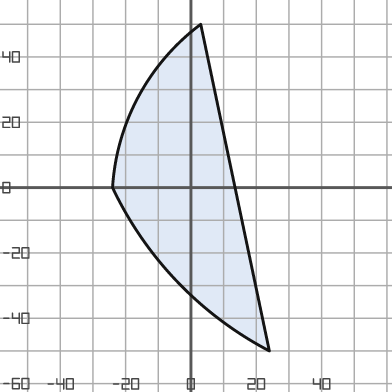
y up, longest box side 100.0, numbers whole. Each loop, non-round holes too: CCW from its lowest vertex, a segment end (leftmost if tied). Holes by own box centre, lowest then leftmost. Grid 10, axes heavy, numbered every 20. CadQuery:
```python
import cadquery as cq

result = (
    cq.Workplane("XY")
    .moveTo(24.0, -50.0)
    .lineTo(3.0, 50.0)
    .threePointArc((-16.0, 28.0), (-24.0, 0.0))
    .threePointArc((-4.0, -29.0), (24.0, -50.0))
    .close()
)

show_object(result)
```